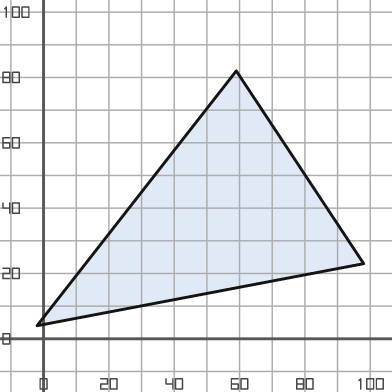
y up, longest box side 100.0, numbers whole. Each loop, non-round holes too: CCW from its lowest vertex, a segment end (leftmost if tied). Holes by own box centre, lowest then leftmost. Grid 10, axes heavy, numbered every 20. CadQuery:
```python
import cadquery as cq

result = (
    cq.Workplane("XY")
    .moveTo(-2.0, 4.0)
    .lineTo(98.0, 23.0)
    .lineTo(59.0, 82.0)
    .close()
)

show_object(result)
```